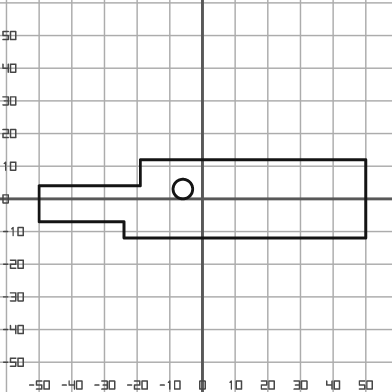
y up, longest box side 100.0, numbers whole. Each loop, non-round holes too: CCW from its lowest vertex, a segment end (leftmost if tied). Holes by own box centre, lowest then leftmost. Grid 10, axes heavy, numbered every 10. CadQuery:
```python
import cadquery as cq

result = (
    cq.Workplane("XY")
    .moveTo(-24.0, -12.0)
    .lineTo(50.0, -12.0)
    .lineTo(50.0, 12.0)
    .lineTo(-19.0, 12.0)
    .lineTo(-19.0, 4.0)
    .lineTo(-50.0, 4.0)
    .lineTo(-50.0, -7.0)
    .lineTo(-24.0, -7.0)
    .close()
    .moveTo(-6.0, 3.0)
    .circle(3.0)
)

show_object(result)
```